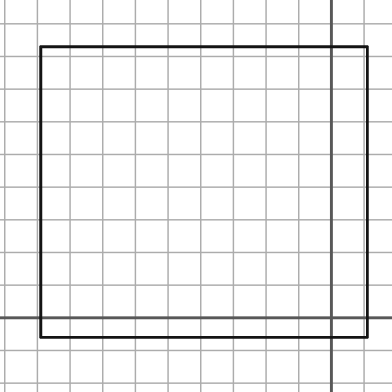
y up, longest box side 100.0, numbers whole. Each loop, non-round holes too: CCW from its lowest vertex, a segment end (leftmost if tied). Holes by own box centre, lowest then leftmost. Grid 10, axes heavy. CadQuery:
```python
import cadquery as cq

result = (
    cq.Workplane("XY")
    .moveTo(-89.0, -6.0)
    .lineTo(11.0, -6.0)
    .lineTo(11.0, 83.0)
    .lineTo(-89.0, 83.0)
    .close()
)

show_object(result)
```